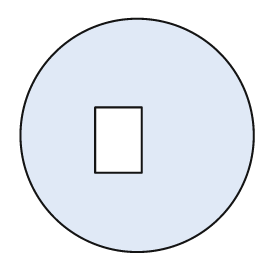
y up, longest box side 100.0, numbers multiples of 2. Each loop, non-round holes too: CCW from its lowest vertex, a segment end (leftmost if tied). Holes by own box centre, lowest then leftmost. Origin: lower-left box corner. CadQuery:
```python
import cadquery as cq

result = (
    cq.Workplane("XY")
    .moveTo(50.0, 50.0)
    .circle(50.0)
    .moveTo(32.0, 34.0)
    .lineTo(52.0, 34.0)
    .lineTo(52.0, 62.0)
    .lineTo(32.0, 62.0)
    .close()
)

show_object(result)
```